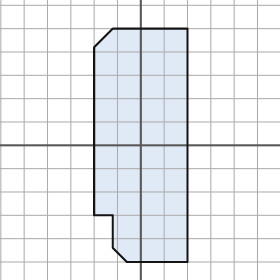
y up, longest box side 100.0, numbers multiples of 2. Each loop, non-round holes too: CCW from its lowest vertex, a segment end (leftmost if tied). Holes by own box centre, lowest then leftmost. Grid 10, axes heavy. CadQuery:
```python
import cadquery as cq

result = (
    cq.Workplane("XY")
    .moveTo(-6.0, -50.0)
    .lineTo(20.0, -50.0)
    .lineTo(20.0, 50.0)
    .lineTo(-12.0, 50.0)
    .lineTo(-20.0, 42.0)
    .lineTo(-20.0, -30.0)
    .lineTo(-12.0, -30.0)
    .lineTo(-12.0, -44.0)
    .close()
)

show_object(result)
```